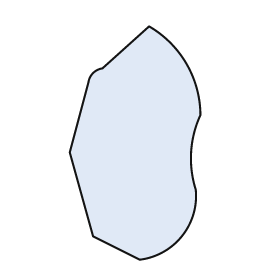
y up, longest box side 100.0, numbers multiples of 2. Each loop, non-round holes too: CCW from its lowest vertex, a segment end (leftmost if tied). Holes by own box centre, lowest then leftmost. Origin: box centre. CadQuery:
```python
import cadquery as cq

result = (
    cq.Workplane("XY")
    .moveTo(2.0, -50.0)
    .threePointArc((20.0, -40.0), (26.0, -20.0))
    .threePointArc((24.0, -4.0), (28.0, 12.0))
    .threePointArc((22.0, 34.0), (6.0, 50.0))
    .lineTo(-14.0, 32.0)
    .threePointArc((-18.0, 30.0), (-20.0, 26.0))
    .lineTo(-28.0, -4.0)
    .lineTo(-18.0, -40.0)
    .close()
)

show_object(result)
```